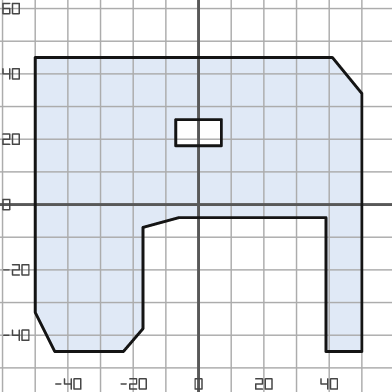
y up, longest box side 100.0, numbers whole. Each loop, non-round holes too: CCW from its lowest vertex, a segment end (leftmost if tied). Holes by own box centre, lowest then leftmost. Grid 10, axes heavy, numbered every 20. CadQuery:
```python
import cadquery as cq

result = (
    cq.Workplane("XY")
    .moveTo(-44.0, -45.0)
    .lineTo(-23.0, -45.0)
    .lineTo(-17.0, -38.0)
    .lineTo(-17.0, -7.0)
    .lineTo(-6.0, -4.0)
    .lineTo(39.0, -4.0)
    .lineTo(39.0, -45.0)
    .lineTo(50.0, -45.0)
    .lineTo(50.0, 34.0)
    .lineTo(41.0, 45.0)
    .lineTo(-50.0, 45.0)
    .lineTo(-50.0, -33.0)
    .close()
    .moveTo(-7.0, 18.0)
    .lineTo(7.0, 18.0)
    .lineTo(7.0, 26.0)
    .lineTo(-7.0, 26.0)
    .close()
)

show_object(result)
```